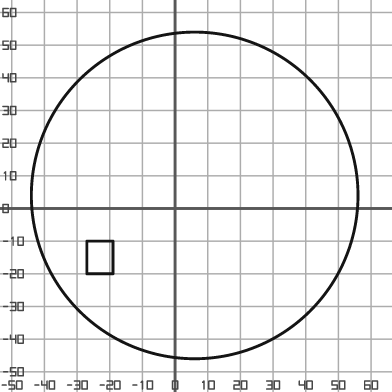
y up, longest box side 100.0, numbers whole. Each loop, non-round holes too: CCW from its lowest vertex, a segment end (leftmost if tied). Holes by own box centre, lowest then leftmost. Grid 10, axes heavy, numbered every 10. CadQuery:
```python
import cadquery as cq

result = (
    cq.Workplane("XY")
    .moveTo(6.0, 4.0)
    .circle(50.0)
    .moveTo(-27.0, -20.0)
    .lineTo(-19.0, -20.0)
    .lineTo(-19.0, -10.0)
    .lineTo(-27.0, -10.0)
    .close()
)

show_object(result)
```